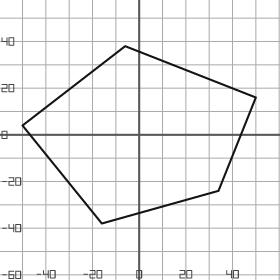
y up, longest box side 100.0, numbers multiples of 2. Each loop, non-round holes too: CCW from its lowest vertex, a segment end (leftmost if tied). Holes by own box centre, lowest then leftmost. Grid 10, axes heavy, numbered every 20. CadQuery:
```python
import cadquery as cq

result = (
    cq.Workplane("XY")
    .moveTo(-16.0, -38.0)
    .lineTo(34.0, -24.0)
    .lineTo(50.0, 16.0)
    .lineTo(-6.0, 38.0)
    .lineTo(-50.0, 4.0)
    .close()
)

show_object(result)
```